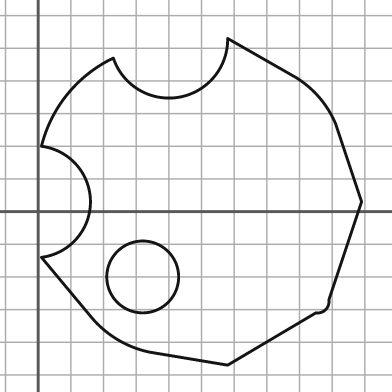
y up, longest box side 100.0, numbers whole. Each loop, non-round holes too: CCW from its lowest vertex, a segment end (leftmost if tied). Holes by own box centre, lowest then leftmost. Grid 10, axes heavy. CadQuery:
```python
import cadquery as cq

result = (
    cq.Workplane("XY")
    .moveTo(58.0, -47.0)
    .lineTo(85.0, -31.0)
    .threePointArc((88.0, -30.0), (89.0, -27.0))
    .lineTo(99.0, 3.0)
    .lineTo(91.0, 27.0)
    .threePointArc((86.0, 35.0), (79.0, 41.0))
    .lineTo(58.0, 53.0)
    .threePointArc((43.0, 35.0), (23.0, 47.0))
    .threePointArc((9.0, 36.0), (1.0, 20.0))
    .threePointArc((16.0, 3.0), (1.0, -14.0))
    .lineTo(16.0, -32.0)
    .threePointArc((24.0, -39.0), (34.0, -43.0))
    .close()
    .moveTo(32.0, -20.0)
    .circle(11.0)
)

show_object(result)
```